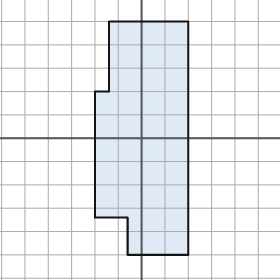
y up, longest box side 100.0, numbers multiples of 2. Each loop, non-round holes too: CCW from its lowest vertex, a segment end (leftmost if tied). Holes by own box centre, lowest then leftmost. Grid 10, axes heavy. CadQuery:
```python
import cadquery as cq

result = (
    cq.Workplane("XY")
    .moveTo(-6.0, -50.0)
    .lineTo(20.0, -50.0)
    .lineTo(20.0, 50.0)
    .lineTo(-14.0, 50.0)
    .lineTo(-14.0, 20.0)
    .lineTo(-20.0, 20.0)
    .lineTo(-20.0, -34.0)
    .lineTo(-6.0, -34.0)
    .close()
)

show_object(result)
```